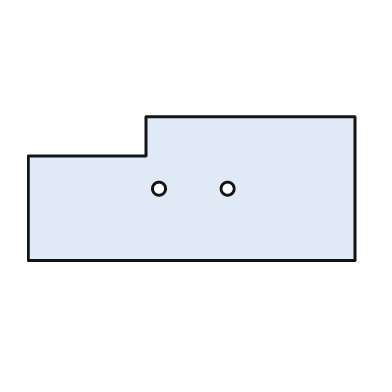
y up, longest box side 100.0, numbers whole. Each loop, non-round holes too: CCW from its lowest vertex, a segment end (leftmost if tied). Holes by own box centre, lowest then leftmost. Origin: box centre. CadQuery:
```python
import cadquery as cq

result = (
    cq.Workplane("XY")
    .moveTo(-50.0, -22.0)
    .lineTo(50.0, -22.0)
    .lineTo(50.0, 22.0)
    .lineTo(-14.0, 22.0)
    .lineTo(-14.0, 10.0)
    .lineTo(-50.0, 10.0)
    .close()
    .moveTo(-10.0, 0.0)
    .circle(2.0)
    .moveTo(11.0, 0.0)
    .circle(2.0)
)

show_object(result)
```